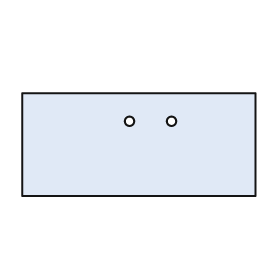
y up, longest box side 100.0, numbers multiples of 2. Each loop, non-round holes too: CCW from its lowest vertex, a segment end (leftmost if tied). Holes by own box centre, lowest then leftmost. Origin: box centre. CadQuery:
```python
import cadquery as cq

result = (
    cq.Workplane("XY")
    .moveTo(-50.0, -22.0)
    .lineTo(50.0, -22.0)
    .lineTo(50.0, 22.0)
    .lineTo(-50.0, 22.0)
    .close()
    .moveTo(-4.0, 10.0)
    .circle(2.0)
    .moveTo(14.0, 10.0)
    .circle(2.0)
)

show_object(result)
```